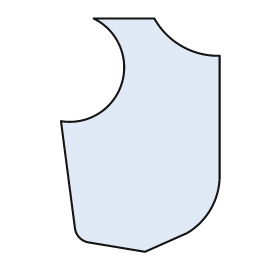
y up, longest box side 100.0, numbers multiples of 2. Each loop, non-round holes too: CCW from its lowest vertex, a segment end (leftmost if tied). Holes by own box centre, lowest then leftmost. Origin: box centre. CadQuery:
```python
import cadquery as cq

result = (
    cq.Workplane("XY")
    .moveTo(2.0, -50.0)
    .lineTo(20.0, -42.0)
    .threePointArc((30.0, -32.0), (34.0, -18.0))
    .lineTo(34.0, 34.0)
    .threePointArc((18.0, 38.0), (6.0, 50.0))
    .lineTo(-20.0, 50.0)
    .threePointArc((-8.0, 22.0), (-34.0, 6.0))
    .lineTo(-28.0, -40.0)
    .threePointArc((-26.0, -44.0), (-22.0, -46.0))
    .close()
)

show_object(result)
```